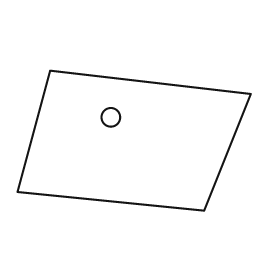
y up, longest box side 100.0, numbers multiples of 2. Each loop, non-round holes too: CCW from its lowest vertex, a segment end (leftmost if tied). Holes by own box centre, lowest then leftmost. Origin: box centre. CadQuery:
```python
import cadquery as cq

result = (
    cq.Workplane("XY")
    .moveTo(30.0, -30.0)
    .lineTo(50.0, 20.0)
    .lineTo(-36.0, 30.0)
    .lineTo(-50.0, -22.0)
    .close()
    .moveTo(-10.0, 10.0)
    .circle(4.0)
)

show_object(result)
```